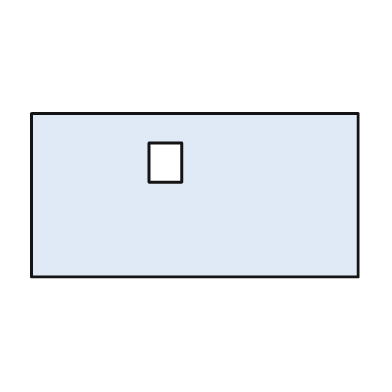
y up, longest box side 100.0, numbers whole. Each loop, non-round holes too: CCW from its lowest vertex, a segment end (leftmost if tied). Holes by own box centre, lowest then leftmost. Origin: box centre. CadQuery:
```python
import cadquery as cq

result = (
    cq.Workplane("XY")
    .moveTo(-50.0, -25.0)
    .lineTo(50.0, -25.0)
    .lineTo(50.0, 25.0)
    .lineTo(-50.0, 25.0)
    .close()
    .moveTo(-14.0, 4.0)
    .lineTo(-4.0, 4.0)
    .lineTo(-4.0, 16.0)
    .lineTo(-14.0, 16.0)
    .close()
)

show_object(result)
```